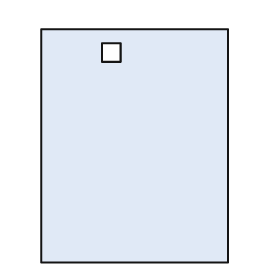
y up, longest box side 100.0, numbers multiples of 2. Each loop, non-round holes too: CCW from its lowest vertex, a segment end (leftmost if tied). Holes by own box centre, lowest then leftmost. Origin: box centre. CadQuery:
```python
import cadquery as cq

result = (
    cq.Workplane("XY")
    .moveTo(-40.0, -50.0)
    .lineTo(40.0, -50.0)
    .lineTo(40.0, 50.0)
    .lineTo(-40.0, 50.0)
    .close()
    .moveTo(-14.0, 36.0)
    .lineTo(-6.0, 36.0)
    .lineTo(-6.0, 44.0)
    .lineTo(-14.0, 44.0)
    .close()
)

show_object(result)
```